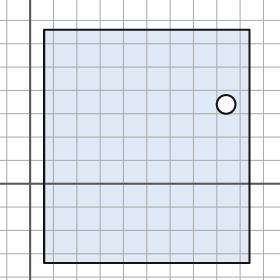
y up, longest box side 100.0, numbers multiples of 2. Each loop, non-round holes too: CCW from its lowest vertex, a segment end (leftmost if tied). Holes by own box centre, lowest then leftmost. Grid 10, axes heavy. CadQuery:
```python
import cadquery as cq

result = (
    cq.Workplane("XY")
    .moveTo(6.0, -34.0)
    .lineTo(94.0, -34.0)
    .lineTo(94.0, 66.0)
    .lineTo(6.0, 66.0)
    .close()
    .moveTo(84.0, 34.0)
    .circle(4.0)
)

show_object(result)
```